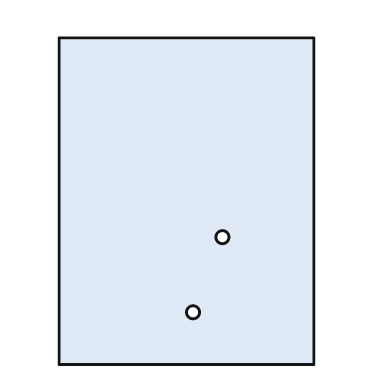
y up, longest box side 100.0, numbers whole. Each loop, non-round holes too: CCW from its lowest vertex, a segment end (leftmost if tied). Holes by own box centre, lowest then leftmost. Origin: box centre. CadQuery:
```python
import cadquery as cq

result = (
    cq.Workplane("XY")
    .moveTo(-39.0, -50.0)
    .lineTo(39.0, -50.0)
    .lineTo(39.0, 50.0)
    .lineTo(-39.0, 50.0)
    .close()
    .moveTo(2.0, -34.0)
    .circle(2.0)
    .moveTo(11.0, -11.0)
    .circle(2.0)
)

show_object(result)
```